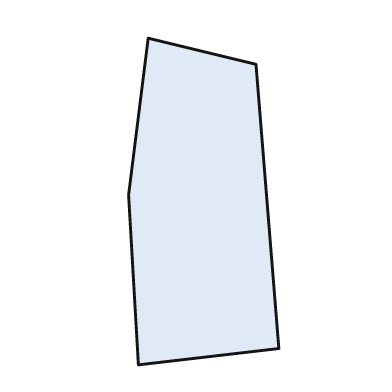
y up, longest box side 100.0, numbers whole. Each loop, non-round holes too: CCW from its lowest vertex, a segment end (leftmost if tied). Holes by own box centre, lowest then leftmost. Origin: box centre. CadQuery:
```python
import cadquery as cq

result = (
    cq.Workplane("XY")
    .moveTo(-20.0, -50.0)
    .lineTo(23.0, -45.0)
    .lineTo(16.0, 42.0)
    .lineTo(-17.0, 50.0)
    .lineTo(-23.0, 2.0)
    .close()
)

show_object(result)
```